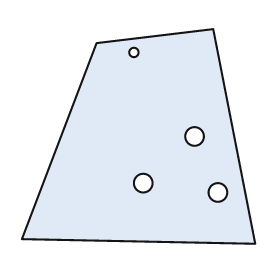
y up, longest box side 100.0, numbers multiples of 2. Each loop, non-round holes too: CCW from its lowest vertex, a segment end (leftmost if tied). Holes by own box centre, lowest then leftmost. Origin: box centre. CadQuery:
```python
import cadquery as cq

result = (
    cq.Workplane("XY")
    .moveTo(50.0, -46.0)
    .lineTo(32.0, 46.0)
    .lineTo(-18.0, 40.0)
    .lineTo(-50.0, -44.0)
    .close()
    .moveTo(34.0, -24.0)
    .circle(4.0)
    .moveTo(2.0, -20.0)
    .circle(4.0)
    .moveTo(24.0, 0.0)
    .circle(4.0)
    .moveTo(-2.0, 36.0)
    .circle(2.0)
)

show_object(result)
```